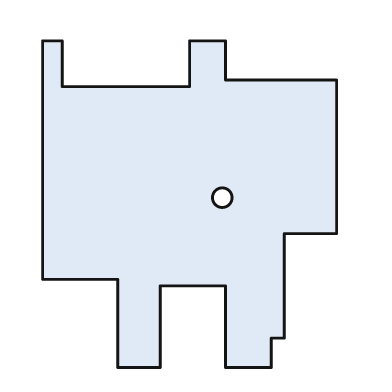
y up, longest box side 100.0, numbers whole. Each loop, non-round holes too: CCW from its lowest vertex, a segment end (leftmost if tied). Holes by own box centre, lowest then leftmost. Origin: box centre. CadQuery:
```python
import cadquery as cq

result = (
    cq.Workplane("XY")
    .moveTo(-22.0, -50.0)
    .lineTo(-9.0, -50.0)
    .lineTo(-9.0, -25.0)
    .lineTo(11.0, -25.0)
    .lineTo(11.0, -50.0)
    .lineTo(25.0, -50.0)
    .lineTo(25.0, -41.0)
    .lineTo(29.0, -41.0)
    .lineTo(29.0, -9.0)
    .lineTo(45.0, -9.0)
    .lineTo(45.0, 38.0)
    .lineTo(11.0, 38.0)
    .lineTo(11.0, 50.0)
    .lineTo(0.0, 50.0)
    .lineTo(0.0, 36.0)
    .lineTo(-39.0, 36.0)
    .lineTo(-39.0, 50.0)
    .lineTo(-45.0, 50.0)
    .lineTo(-45.0, -23.0)
    .lineTo(-22.0, -23.0)
    .close()
    .moveTo(10.0, 2.0)
    .circle(3.0)
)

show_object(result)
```